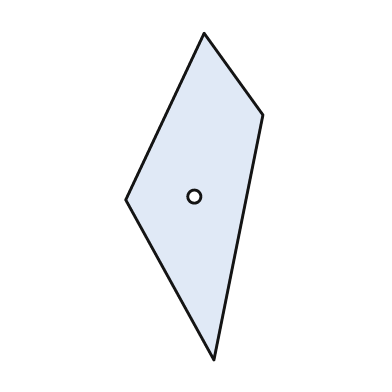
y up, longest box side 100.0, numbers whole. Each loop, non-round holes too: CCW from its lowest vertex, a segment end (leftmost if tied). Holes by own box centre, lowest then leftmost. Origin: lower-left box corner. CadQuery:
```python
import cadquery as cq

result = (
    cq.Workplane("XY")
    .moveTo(27.0, 0.0)
    .lineTo(42.0, 75.0)
    .lineTo(24.0, 100.0)
    .lineTo(0.0, 49.0)
    .close()
    .moveTo(21.0, 50.0)
    .circle(2.0)
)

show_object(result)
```